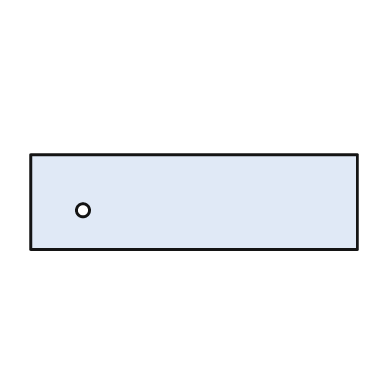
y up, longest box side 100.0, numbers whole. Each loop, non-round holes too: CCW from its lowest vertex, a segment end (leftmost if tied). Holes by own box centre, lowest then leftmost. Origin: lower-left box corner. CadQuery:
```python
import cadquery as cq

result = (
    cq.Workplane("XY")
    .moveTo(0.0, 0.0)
    .lineTo(100.0, 0.0)
    .lineTo(100.0, 29.0)
    .lineTo(0.0, 29.0)
    .close()
    .moveTo(16.0, 12.0)
    .circle(2.0)
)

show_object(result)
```